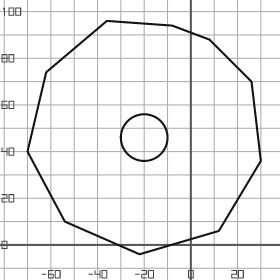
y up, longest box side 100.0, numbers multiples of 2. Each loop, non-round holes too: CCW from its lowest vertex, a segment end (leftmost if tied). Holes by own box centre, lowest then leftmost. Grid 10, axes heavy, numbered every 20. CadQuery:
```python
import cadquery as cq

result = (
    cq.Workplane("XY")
    .moveTo(-22.0, -4.0)
    .lineTo(12.0, 6.0)
    .lineTo(30.0, 36.0)
    .lineTo(26.0, 70.0)
    .lineTo(8.0, 88.0)
    .lineTo(-8.0, 94.0)
    .lineTo(-36.0, 96.0)
    .lineTo(-62.0, 74.0)
    .lineTo(-70.0, 40.0)
    .lineTo(-54.0, 10.0)
    .close()
    .moveTo(-20.0, 46.0)
    .circle(10.0)
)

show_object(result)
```